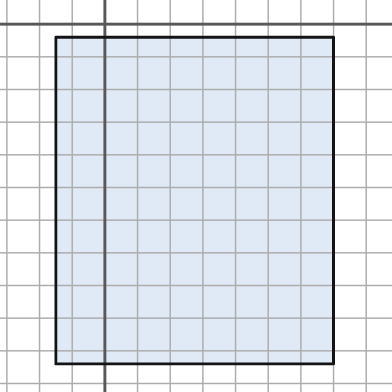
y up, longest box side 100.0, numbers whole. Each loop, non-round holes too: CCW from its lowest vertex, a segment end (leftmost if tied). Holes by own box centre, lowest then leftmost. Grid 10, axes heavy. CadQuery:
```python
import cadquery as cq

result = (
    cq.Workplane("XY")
    .moveTo(-15.0, -104.0)
    .lineTo(70.0, -104.0)
    .lineTo(70.0, -4.0)
    .lineTo(-15.0, -4.0)
    .close()
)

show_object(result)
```